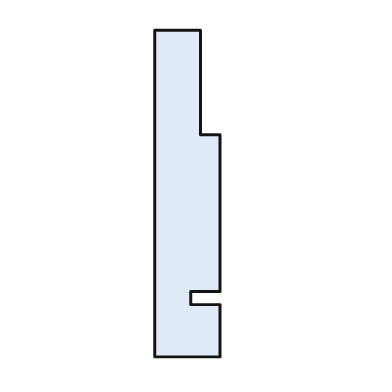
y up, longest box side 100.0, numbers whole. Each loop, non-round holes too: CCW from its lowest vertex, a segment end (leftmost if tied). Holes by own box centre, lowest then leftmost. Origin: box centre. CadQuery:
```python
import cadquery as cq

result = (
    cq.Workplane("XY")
    .moveTo(-10.0, -50.0)
    .lineTo(10.0, -50.0)
    .lineTo(10.0, -34.0)
    .lineTo(1.0, -34.0)
    .lineTo(1.0, -30.0)
    .lineTo(10.0, -30.0)
    .lineTo(10.0, 18.0)
    .lineTo(4.0, 18.0)
    .lineTo(4.0, 50.0)
    .lineTo(-10.0, 50.0)
    .close()
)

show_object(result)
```